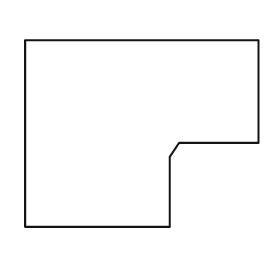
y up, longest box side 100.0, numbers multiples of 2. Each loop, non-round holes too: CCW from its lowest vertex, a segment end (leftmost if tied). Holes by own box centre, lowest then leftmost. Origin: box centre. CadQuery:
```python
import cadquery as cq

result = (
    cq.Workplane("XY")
    .moveTo(-50.0, -40.0)
    .lineTo(12.0, -40.0)
    .lineTo(12.0, -10.0)
    .lineTo(16.0, -4.0)
    .lineTo(50.0, -4.0)
    .lineTo(50.0, 40.0)
    .lineTo(-50.0, 40.0)
    .close()
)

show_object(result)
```